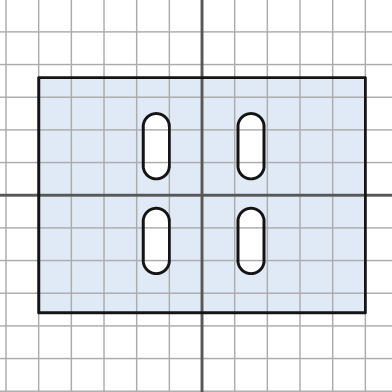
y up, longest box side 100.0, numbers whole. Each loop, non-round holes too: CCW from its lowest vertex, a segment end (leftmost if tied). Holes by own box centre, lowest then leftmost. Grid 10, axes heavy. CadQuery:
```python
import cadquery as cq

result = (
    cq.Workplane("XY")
    .moveTo(-50.0, -36.0)
    .lineTo(50.0, -36.0)
    .lineTo(50.0, 36.0)
    .lineTo(-50.0, 36.0)
    .close()
    .moveTo(-18.0, -20.0)
    .threePointArc((-14.0, -24.0), (-10.0, -20.0))
    .lineTo(-10.0, -8.0)
    .threePointArc((-14.0, -4.0), (-18.0, -8.0))
    .close()
    .moveTo(11.0, -20.0)
    .threePointArc((15.0, -24.0), (19.0, -20.0))
    .lineTo(19.0, -8.0)
    .threePointArc((15.0, -4.0), (11.0, -8.0))
    .close()
    .moveTo(-18.0, 9.0)
    .threePointArc((-14.0, 5.0), (-10.0, 9.0))
    .lineTo(-10.0, 21.0)
    .threePointArc((-14.0, 25.0), (-18.0, 21.0))
    .close()
    .moveTo(11.0, 9.0)
    .threePointArc((15.0, 5.0), (19.0, 9.0))
    .lineTo(19.0, 21.0)
    .threePointArc((15.0, 25.0), (11.0, 21.0))
    .close()
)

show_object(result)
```